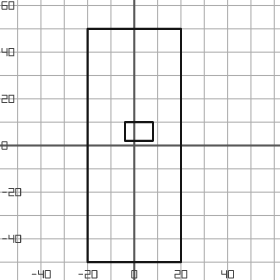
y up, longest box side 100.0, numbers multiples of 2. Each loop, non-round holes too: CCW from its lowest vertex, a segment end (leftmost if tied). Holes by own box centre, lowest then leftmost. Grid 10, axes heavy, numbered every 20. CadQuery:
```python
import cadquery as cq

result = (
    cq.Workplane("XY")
    .moveTo(-20.0, -50.0)
    .lineTo(20.0, -50.0)
    .lineTo(20.0, 50.0)
    .lineTo(-20.0, 50.0)
    .close()
    .moveTo(-4.0, 2.0)
    .lineTo(8.0, 2.0)
    .lineTo(8.0, 10.0)
    .lineTo(-4.0, 10.0)
    .close()
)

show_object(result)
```